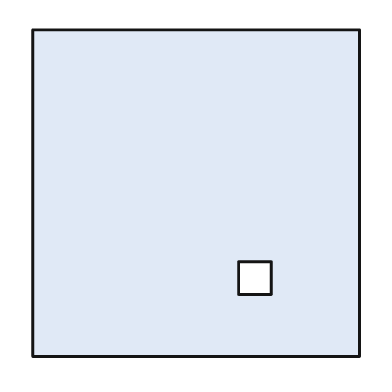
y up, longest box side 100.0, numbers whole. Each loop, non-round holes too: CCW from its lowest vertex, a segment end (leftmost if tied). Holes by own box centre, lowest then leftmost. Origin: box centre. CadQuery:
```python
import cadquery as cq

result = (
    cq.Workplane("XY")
    .moveTo(-50.0, -50.0)
    .lineTo(50.0, -50.0)
    .lineTo(50.0, 50.0)
    .lineTo(-50.0, 50.0)
    .close()
    .moveTo(13.0, -31.0)
    .lineTo(23.0, -31.0)
    .lineTo(23.0, -21.0)
    .lineTo(13.0, -21.0)
    .close()
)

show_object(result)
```